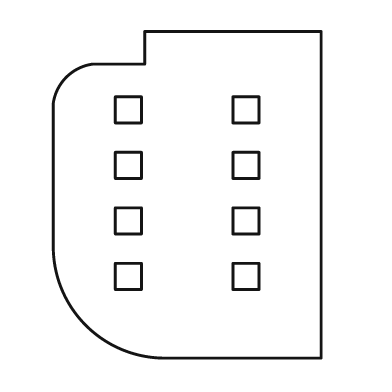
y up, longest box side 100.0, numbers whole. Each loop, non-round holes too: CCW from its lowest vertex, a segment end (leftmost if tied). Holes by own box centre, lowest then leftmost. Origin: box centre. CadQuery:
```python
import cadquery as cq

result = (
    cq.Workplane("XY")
    .moveTo(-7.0, -50.0)
    .lineTo(41.0, -50.0)
    .lineTo(41.0, 50.0)
    .lineTo(-13.0, 50.0)
    .lineTo(-13.0, 40.0)
    .lineTo(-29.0, 40.0)
    .threePointArc((-37.0, 36.0), (-41.0, 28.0))
    .lineTo(-41.0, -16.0)
    .threePointArc((-31.0, -40.0), (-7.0, -50.0))
    .close()
    .moveTo(-22.0, -29.0)
    .lineTo(-14.0, -29.0)
    .lineTo(-14.0, -21.0)
    .lineTo(-22.0, -21.0)
    .close()
    .moveTo(14.0, -29.0)
    .lineTo(22.0, -29.0)
    .lineTo(22.0, -21.0)
    .lineTo(14.0, -21.0)
    .close()
    .moveTo(-22.0, -12.0)
    .lineTo(-14.0, -12.0)
    .lineTo(-14.0, -4.0)
    .lineTo(-22.0, -4.0)
    .close()
    .moveTo(14.0, -12.0)
    .lineTo(22.0, -12.0)
    .lineTo(22.0, -4.0)
    .lineTo(14.0, -4.0)
    .close()
    .moveTo(-22.0, 5.0)
    .lineTo(-14.0, 5.0)
    .lineTo(-14.0, 13.0)
    .lineTo(-22.0, 13.0)
    .close()
    .moveTo(14.0, 5.0)
    .lineTo(22.0, 5.0)
    .lineTo(22.0, 13.0)
    .lineTo(14.0, 13.0)
    .close()
    .moveTo(-22.0, 22.0)
    .lineTo(-14.0, 22.0)
    .lineTo(-14.0, 30.0)
    .lineTo(-22.0, 30.0)
    .close()
    .moveTo(14.0, 22.0)
    .lineTo(22.0, 22.0)
    .lineTo(22.0, 30.0)
    .lineTo(14.0, 30.0)
    .close()
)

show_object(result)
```